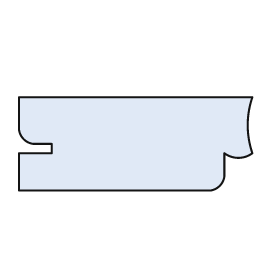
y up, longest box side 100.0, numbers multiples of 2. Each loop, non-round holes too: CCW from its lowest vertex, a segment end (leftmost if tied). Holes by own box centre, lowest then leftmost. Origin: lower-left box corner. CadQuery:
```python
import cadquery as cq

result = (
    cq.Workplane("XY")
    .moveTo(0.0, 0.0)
    .lineTo(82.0, 0.0)
    .threePointArc((86.0, 2.0), (88.0, 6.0))
    .lineTo(88.0, 16.0)
    .threePointArc((94.0, 14.0), (100.0, 16.0))
    .threePointArc((98.0, 28.0), (100.0, 40.0))
    .lineTo(0.0, 40.0)
    .lineTo(0.0, 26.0)
    .threePointArc((2.0, 22.0), (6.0, 20.0))
    .lineTo(14.0, 20.0)
    .lineTo(14.0, 16.0)
    .lineTo(0.0, 16.0)
    .close()
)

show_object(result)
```